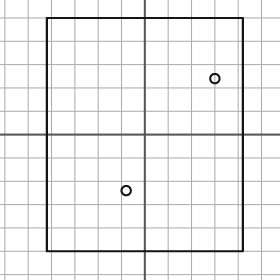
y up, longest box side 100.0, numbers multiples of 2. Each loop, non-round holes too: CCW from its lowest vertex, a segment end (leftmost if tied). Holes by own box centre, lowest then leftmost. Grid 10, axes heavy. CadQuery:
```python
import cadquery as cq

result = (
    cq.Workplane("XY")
    .moveTo(-42.0, -50.0)
    .lineTo(42.0, -50.0)
    .lineTo(42.0, 50.0)
    .lineTo(-42.0, 50.0)
    .close()
    .moveTo(-8.0, -24.0)
    .circle(2.0)
    .moveTo(30.0, 24.0)
    .circle(2.0)
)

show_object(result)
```